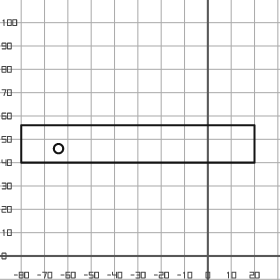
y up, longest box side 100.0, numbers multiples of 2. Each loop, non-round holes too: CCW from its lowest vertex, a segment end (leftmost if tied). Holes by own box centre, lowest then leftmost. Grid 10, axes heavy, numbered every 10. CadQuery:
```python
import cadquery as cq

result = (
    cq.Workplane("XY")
    .moveTo(-80.0, 40.0)
    .lineTo(20.0, 40.0)
    .lineTo(20.0, 56.0)
    .lineTo(-80.0, 56.0)
    .close()
    .moveTo(-64.0, 46.0)
    .circle(2.0)
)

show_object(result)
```